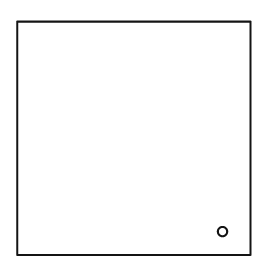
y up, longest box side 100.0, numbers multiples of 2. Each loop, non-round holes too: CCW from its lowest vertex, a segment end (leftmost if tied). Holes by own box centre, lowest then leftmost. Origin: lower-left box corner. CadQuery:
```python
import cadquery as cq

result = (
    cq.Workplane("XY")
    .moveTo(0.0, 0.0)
    .lineTo(100.0, 0.0)
    .lineTo(100.0, 100.0)
    .lineTo(0.0, 100.0)
    .close()
    .moveTo(88.0, 10.0)
    .circle(2.0)
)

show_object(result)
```